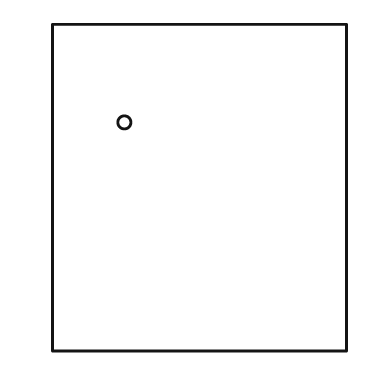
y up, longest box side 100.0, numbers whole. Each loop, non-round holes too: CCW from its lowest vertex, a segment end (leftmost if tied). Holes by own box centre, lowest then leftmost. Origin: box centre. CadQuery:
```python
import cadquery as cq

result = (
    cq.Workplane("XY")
    .moveTo(-45.0, -50.0)
    .lineTo(45.0, -50.0)
    .lineTo(45.0, 50.0)
    .lineTo(-45.0, 50.0)
    .close()
    .moveTo(-23.0, 20.0)
    .circle(2.0)
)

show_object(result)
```